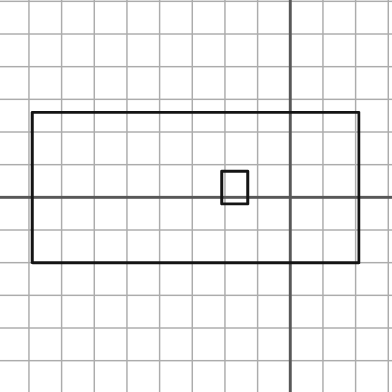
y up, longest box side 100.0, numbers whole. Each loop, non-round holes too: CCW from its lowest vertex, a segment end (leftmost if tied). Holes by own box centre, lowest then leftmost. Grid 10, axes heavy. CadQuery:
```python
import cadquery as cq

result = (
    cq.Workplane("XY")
    .moveTo(-79.0, -20.0)
    .lineTo(21.0, -20.0)
    .lineTo(21.0, 26.0)
    .lineTo(-79.0, 26.0)
    .close()
    .moveTo(-21.0, -2.0)
    .lineTo(-13.0, -2.0)
    .lineTo(-13.0, 8.0)
    .lineTo(-21.0, 8.0)
    .close()
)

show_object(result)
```